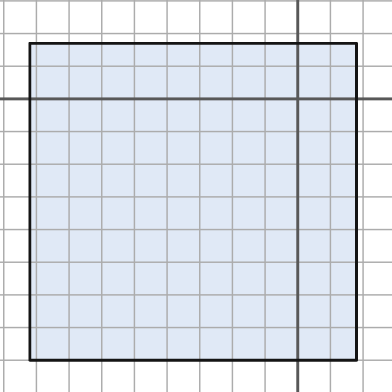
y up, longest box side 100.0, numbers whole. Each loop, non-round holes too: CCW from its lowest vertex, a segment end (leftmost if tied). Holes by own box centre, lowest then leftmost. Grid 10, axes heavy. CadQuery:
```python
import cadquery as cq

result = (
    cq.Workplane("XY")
    .moveTo(-82.0, -80.0)
    .lineTo(18.0, -80.0)
    .lineTo(18.0, 17.0)
    .lineTo(-82.0, 17.0)
    .close()
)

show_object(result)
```